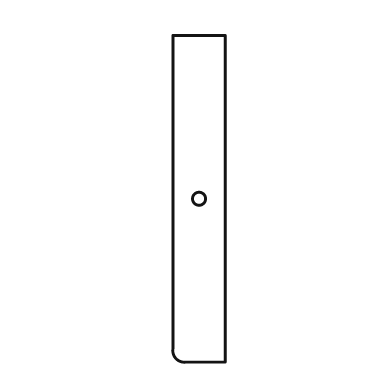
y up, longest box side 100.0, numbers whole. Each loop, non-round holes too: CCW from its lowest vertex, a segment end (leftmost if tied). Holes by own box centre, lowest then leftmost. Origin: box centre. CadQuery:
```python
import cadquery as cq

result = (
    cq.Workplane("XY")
    .moveTo(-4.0, -50.0)
    .lineTo(8.0, -50.0)
    .lineTo(8.0, 50.0)
    .lineTo(-8.0, 50.0)
    .lineTo(-8.0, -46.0)
    .threePointArc((-7.0, -49.0), (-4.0, -50.0))
    .close()
    .moveTo(0.0, 0.0)
    .circle(2.0)
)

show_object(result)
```